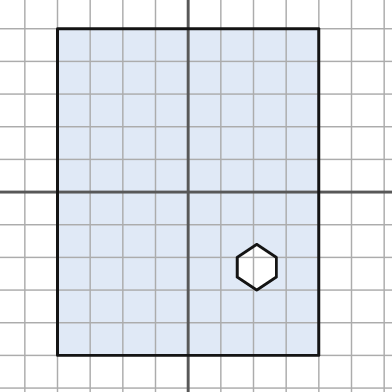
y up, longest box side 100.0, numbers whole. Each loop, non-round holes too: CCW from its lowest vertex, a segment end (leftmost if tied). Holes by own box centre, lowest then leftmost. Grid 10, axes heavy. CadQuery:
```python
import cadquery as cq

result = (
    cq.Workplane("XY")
    .moveTo(-40.0, -50.0)
    .lineTo(40.0, -50.0)
    .lineTo(40.0, 50.0)
    .lineTo(-40.0, 50.0)
    .close()
    .moveTo(21.0, -30.0)
    .lineTo(27.0, -26.0)
    .lineTo(27.0, -20.0)
    .lineTo(21.0, -16.0)
    .lineTo(15.0, -20.0)
    .lineTo(15.0, -26.0)
    .close()
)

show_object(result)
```